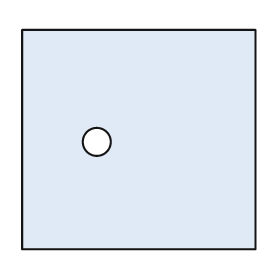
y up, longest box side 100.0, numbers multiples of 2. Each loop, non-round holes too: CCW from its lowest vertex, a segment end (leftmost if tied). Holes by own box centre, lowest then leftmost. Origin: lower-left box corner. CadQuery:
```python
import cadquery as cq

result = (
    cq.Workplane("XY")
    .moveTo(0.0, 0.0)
    .lineTo(100.0, 0.0)
    .lineTo(100.0, 94.0)
    .lineTo(0.0, 94.0)
    .close()
    .moveTo(32.0, 46.0)
    .circle(6.0)
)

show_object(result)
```